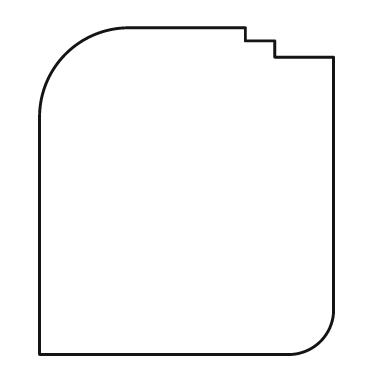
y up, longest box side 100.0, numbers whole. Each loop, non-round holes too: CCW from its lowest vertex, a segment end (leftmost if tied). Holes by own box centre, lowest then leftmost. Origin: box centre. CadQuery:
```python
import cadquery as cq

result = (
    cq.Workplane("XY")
    .moveTo(-45.0, -50.0)
    .lineTo(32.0, -50.0)
    .threePointArc((41.0, -46.0), (45.0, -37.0))
    .lineTo(45.0, 41.0)
    .lineTo(27.0, 41.0)
    .lineTo(27.0, 46.0)
    .lineTo(18.0, 46.0)
    .lineTo(18.0, 50.0)
    .lineTo(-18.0, 50.0)
    .threePointArc((-37.0, 42.0), (-45.0, 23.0))
    .close()
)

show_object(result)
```